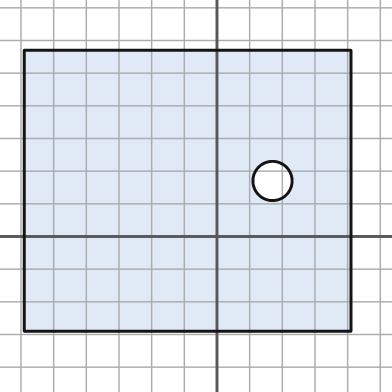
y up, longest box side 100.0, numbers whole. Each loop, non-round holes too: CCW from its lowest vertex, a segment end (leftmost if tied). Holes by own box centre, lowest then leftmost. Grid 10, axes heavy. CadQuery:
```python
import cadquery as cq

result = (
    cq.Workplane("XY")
    .moveTo(-59.0, -29.0)
    .lineTo(41.0, -29.0)
    .lineTo(41.0, 57.0)
    .lineTo(-59.0, 57.0)
    .close()
    .moveTo(17.0, 17.0)
    .circle(6.0)
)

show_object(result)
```